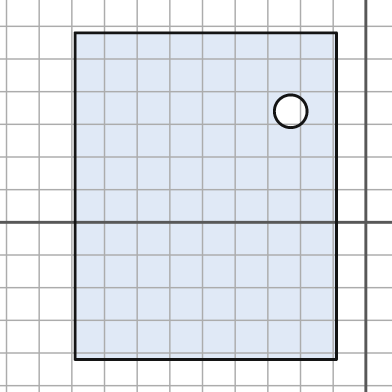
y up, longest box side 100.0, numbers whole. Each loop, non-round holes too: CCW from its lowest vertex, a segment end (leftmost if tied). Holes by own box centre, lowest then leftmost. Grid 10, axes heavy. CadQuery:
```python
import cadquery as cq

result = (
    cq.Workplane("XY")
    .moveTo(-89.0, -42.0)
    .lineTo(-9.0, -42.0)
    .lineTo(-9.0, 58.0)
    .lineTo(-89.0, 58.0)
    .close()
    .moveTo(-23.0, 34.0)
    .circle(5.0)
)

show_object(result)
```